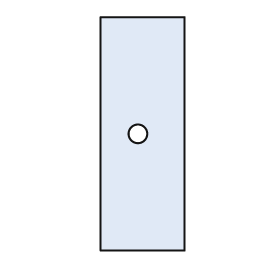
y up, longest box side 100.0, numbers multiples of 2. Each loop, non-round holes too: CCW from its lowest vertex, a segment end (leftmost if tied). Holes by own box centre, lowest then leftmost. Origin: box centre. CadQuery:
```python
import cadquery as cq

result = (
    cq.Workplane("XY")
    .moveTo(-18.0, -50.0)
    .lineTo(18.0, -50.0)
    .lineTo(18.0, 50.0)
    .lineTo(-18.0, 50.0)
    .close()
    .moveTo(-2.0, 0.0)
    .circle(4.0)
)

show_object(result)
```